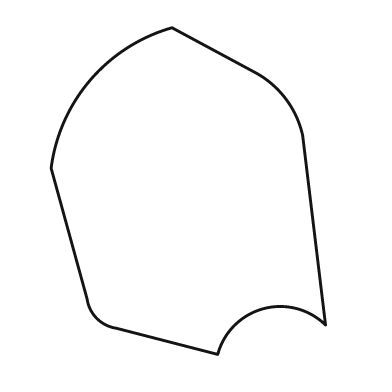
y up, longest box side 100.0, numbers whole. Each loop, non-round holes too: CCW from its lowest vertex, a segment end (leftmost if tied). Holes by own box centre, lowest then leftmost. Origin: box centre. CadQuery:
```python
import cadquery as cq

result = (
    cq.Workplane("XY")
    .moveTo(9.0, -50.0)
    .threePointArc((23.0, -36.0), (42.0, -41.0))
    .lineTo(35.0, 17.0)
    .threePointArc((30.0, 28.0), (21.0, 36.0))
    .lineTo(-5.0, 50.0)
    .threePointArc((-30.0, 34.0), (-42.0, 7.0))
    .lineTo(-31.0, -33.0)
    .threePointArc((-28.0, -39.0), (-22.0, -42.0))
    .close()
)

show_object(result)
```